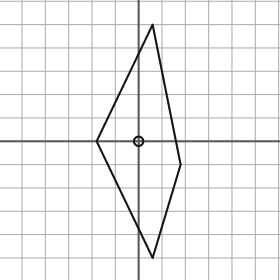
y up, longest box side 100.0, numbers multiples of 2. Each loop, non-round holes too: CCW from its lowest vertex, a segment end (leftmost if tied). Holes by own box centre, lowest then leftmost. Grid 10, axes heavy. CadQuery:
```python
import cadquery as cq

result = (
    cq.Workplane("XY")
    .moveTo(6.0, -50.0)
    .lineTo(18.0, -10.0)
    .lineTo(6.0, 50.0)
    .lineTo(-18.0, 0.0)
    .close()
    .moveTo(0.0, 0.0)
    .circle(2.0)
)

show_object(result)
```